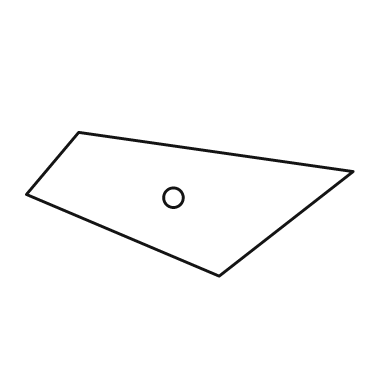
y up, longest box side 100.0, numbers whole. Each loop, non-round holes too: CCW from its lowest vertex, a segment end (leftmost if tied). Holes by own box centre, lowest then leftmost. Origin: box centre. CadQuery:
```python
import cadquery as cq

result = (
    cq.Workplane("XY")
    .moveTo(9.0, -22.0)
    .lineTo(50.0, 10.0)
    .lineTo(-34.0, 22.0)
    .lineTo(-50.0, 3.0)
    .close()
    .moveTo(-5.0, 2.0)
    .circle(3.0)
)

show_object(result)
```